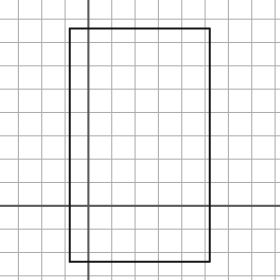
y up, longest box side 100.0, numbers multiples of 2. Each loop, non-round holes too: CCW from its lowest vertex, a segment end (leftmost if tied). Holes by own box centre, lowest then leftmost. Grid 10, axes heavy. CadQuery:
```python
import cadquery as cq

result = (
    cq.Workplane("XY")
    .moveTo(-8.0, -24.0)
    .lineTo(52.0, -24.0)
    .lineTo(52.0, 76.0)
    .lineTo(-8.0, 76.0)
    .close()
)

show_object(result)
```